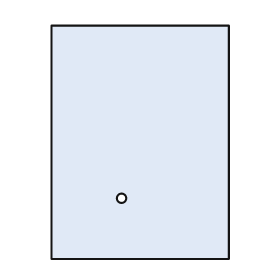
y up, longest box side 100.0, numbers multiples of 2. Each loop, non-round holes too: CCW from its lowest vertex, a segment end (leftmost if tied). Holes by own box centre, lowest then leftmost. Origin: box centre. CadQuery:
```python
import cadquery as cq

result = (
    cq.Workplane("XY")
    .moveTo(-38.0, -50.0)
    .lineTo(38.0, -50.0)
    .lineTo(38.0, 50.0)
    .lineTo(-38.0, 50.0)
    .close()
    .moveTo(-8.0, -24.0)
    .circle(2.0)
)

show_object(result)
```